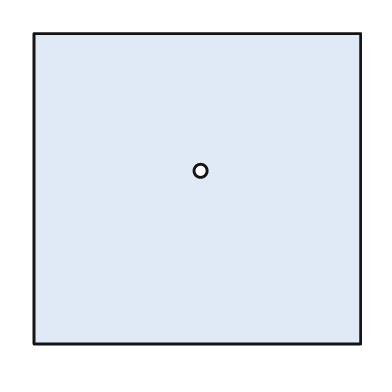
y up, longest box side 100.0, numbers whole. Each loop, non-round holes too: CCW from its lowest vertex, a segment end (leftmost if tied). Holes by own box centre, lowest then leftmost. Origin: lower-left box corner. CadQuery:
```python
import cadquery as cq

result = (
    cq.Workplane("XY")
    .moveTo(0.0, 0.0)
    .lineTo(100.0, 0.0)
    .lineTo(100.0, 95.0)
    .lineTo(0.0, 95.0)
    .close()
    .moveTo(51.0, 53.0)
    .circle(2.0)
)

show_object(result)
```